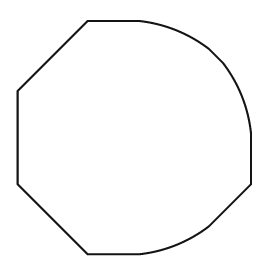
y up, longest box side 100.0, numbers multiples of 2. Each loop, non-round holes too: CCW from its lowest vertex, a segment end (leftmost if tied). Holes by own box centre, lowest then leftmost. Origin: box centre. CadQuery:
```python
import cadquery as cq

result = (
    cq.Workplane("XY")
    .moveTo(-20.0, -50.0)
    .lineTo(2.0, -50.0)
    .threePointArc((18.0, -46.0), (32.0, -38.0))
    .lineTo(50.0, -20.0)
    .lineTo(50.0, 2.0)
    .threePointArc((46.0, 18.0), (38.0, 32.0))
    .lineTo(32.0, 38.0)
    .threePointArc((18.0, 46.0), (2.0, 50.0))
    .lineTo(-20.0, 50.0)
    .lineTo(-50.0, 20.0)
    .lineTo(-50.0, -20.0)
    .close()
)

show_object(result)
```